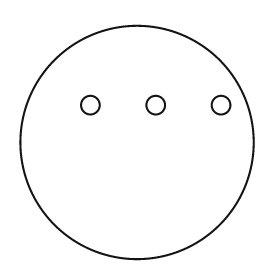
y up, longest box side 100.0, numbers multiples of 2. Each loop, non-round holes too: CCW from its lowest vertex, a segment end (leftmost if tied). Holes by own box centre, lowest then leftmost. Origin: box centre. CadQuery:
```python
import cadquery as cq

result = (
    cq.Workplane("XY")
    .moveTo(0.0, 0.0)
    .circle(50.0)
    .moveTo(-20.0, 16.0)
    .circle(4.0)
    .moveTo(8.0, 16.0)
    .circle(4.0)
    .moveTo(36.0, 16.0)
    .circle(4.0)
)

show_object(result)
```